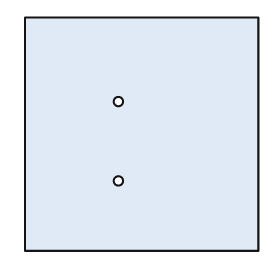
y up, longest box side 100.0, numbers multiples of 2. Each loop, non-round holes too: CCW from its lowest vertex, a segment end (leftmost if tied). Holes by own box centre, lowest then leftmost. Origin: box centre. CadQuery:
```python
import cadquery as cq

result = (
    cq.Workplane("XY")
    .moveTo(-50.0, -50.0)
    .lineTo(50.0, -50.0)
    .lineTo(50.0, 50.0)
    .lineTo(-50.0, 50.0)
    .close()
    .moveTo(-10.0, -20.0)
    .circle(2.0)
    .moveTo(-10.0, 14.0)
    .circle(2.0)
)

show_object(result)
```